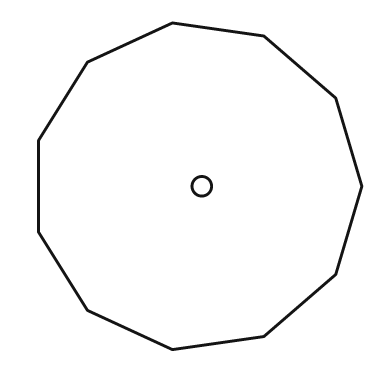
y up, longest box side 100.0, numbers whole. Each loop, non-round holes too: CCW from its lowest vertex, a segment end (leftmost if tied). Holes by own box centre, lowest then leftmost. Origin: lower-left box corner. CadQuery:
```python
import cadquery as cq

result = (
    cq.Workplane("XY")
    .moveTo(41.0, 0.0)
    .lineTo(69.0, 4.0)
    .lineTo(91.0, 23.0)
    .lineTo(99.0, 50.0)
    .lineTo(91.0, 77.0)
    .lineTo(69.0, 96.0)
    .lineTo(41.0, 100.0)
    .lineTo(15.0, 88.0)
    .lineTo(0.0, 64.0)
    .lineTo(0.0, 36.0)
    .lineTo(15.0, 12.0)
    .close()
    .moveTo(50.0, 50.0)
    .circle(3.0)
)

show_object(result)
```